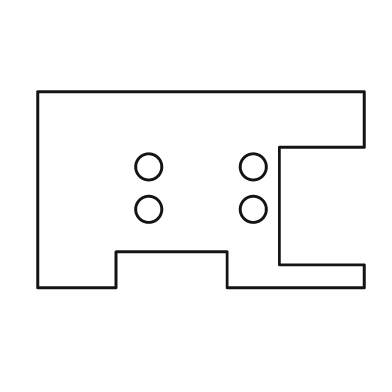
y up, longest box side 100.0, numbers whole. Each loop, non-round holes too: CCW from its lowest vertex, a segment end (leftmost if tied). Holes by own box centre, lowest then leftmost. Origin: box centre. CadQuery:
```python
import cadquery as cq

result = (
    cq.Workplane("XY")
    .moveTo(-50.0, -30.0)
    .lineTo(-26.0, -30.0)
    .lineTo(-26.0, -19.0)
    .lineTo(8.0, -19.0)
    .lineTo(8.0, -30.0)
    .lineTo(50.0, -30.0)
    .lineTo(50.0, -23.0)
    .lineTo(24.0, -23.0)
    .lineTo(24.0, 13.0)
    .lineTo(50.0, 13.0)
    .lineTo(50.0, 30.0)
    .lineTo(-50.0, 30.0)
    .close()
    .moveTo(-16.0, -6.0)
    .circle(4.0)
    .moveTo(16.0, -6.0)
    .circle(4.0)
    .moveTo(-16.0, 7.0)
    .circle(4.0)
    .moveTo(16.0, 7.0)
    .circle(4.0)
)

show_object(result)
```